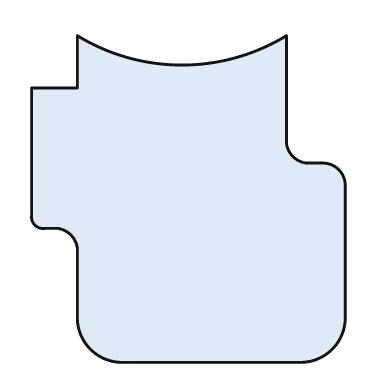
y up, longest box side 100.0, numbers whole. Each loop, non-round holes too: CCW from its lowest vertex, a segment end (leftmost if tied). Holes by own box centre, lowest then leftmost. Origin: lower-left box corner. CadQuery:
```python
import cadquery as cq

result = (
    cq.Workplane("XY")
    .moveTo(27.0, 0.0)
    .lineTo(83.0, 0.0)
    .threePointArc((92.0, 4.0), (96.0, 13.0))
    .lineTo(96.0, 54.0)
    .threePointArc((94.0, 59.0), (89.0, 61.0))
    .lineTo(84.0, 61.0)
    .threePointArc((80.0, 63.0), (78.0, 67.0))
    .lineTo(78.0, 100.0)
    .threePointArc((46.0, 91.0), (14.0, 100.0))
    .lineTo(14.0, 84.0)
    .lineTo(0.0, 84.0)
    .lineTo(0.0, 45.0)
    .threePointArc((1.0, 42.0), (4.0, 41.0))
    .lineTo(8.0, 41.0)
    .threePointArc((12.0, 39.0), (14.0, 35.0))
    .lineTo(14.0, 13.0)
    .threePointArc((18.0, 4.0), (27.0, 0.0))
    .close()
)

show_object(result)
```